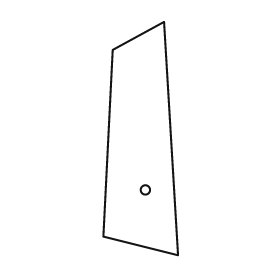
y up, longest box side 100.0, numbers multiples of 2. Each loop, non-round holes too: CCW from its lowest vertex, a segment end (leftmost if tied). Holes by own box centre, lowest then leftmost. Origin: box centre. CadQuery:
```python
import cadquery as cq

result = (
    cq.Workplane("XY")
    .moveTo(16.0, -50.0)
    .lineTo(10.0, 50.0)
    .lineTo(-12.0, 38.0)
    .lineTo(-16.0, -42.0)
    .close()
    .moveTo(2.0, -22.0)
    .circle(2.0)
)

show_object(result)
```